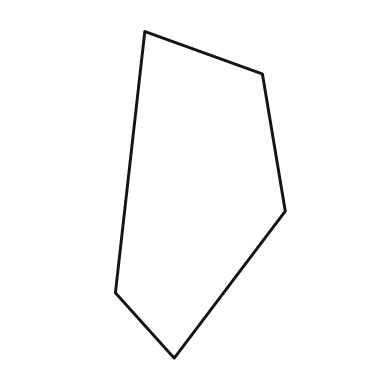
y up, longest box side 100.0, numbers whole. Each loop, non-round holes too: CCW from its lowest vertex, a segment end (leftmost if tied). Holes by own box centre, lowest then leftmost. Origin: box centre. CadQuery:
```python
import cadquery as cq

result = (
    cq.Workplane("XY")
    .moveTo(-8.0, -50.0)
    .lineTo(26.0, -5.0)
    .lineTo(19.0, 37.0)
    .lineTo(-17.0, 50.0)
    .lineTo(-26.0, -30.0)
    .close()
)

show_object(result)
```